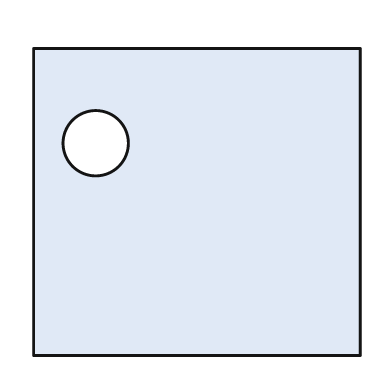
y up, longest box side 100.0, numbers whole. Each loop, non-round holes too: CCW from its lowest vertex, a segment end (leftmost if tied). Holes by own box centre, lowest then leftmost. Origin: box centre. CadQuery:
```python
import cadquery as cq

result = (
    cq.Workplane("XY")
    .moveTo(-50.0, -47.0)
    .lineTo(50.0, -47.0)
    .lineTo(50.0, 47.0)
    .lineTo(-50.0, 47.0)
    .close()
    .moveTo(-31.0, 18.0)
    .circle(10.0)
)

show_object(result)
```